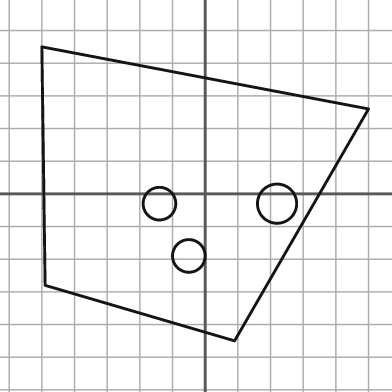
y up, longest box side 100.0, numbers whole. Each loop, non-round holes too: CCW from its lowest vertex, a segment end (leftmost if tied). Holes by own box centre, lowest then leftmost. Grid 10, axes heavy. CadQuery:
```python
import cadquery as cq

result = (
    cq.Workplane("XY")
    .moveTo(9.0, -45.0)
    .lineTo(50.0, 26.0)
    .lineTo(-50.0, 45.0)
    .lineTo(-49.0, -28.0)
    .close()
    .moveTo(-5.0, -19.0)
    .circle(5.0)
    .moveTo(-14.0, -3.0)
    .circle(5.0)
    .moveTo(22.0, -3.0)
    .circle(6.0)
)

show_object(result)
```